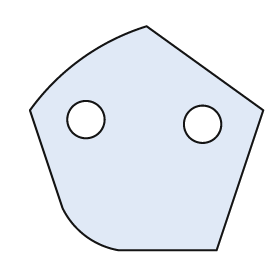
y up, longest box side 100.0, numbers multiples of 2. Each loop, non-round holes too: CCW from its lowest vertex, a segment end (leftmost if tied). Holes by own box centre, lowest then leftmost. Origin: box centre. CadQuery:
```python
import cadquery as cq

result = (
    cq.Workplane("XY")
    .moveTo(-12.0, -48.0)
    .lineTo(30.0, -48.0)
    .lineTo(50.0, 12.0)
    .lineTo(0.0, 48.0)
    .threePointArc((-28.0, 34.0), (-50.0, 12.0))
    .lineTo(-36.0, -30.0)
    .threePointArc((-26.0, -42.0), (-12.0, -48.0))
    .close()
    .moveTo(24.0, 6.0)
    .circle(8.0)
    .moveTo(-26.0, 8.0)
    .circle(8.0)
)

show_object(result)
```